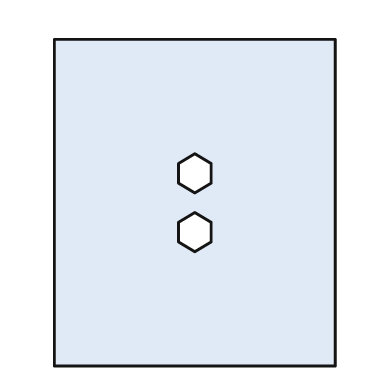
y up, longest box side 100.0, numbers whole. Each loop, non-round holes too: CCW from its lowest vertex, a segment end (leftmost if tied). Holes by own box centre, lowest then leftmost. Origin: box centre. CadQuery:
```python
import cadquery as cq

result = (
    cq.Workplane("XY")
    .moveTo(-43.0, -50.0)
    .lineTo(43.0, -50.0)
    .lineTo(43.0, 50.0)
    .lineTo(-43.0, 50.0)
    .close()
    .moveTo(0.0, -15.0)
    .lineTo(5.0, -12.0)
    .lineTo(5.0, -6.0)
    .lineTo(0.0, -3.0)
    .lineTo(-5.0, -6.0)
    .lineTo(-5.0, -12.0)
    .close()
    .moveTo(0.0, 3.0)
    .lineTo(5.0, 6.0)
    .lineTo(5.0, 12.0)
    .lineTo(0.0, 15.0)
    .lineTo(-5.0, 12.0)
    .lineTo(-5.0, 6.0)
    .close()
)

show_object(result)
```